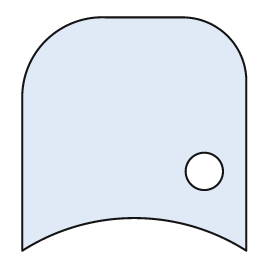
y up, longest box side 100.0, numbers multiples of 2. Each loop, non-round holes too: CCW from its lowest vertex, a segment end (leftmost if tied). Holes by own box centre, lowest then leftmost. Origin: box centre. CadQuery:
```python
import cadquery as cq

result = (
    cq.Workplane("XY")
    .moveTo(-48.0, -50.0)
    .threePointArc((0.0, -36.0), (48.0, -50.0))
    .lineTo(48.0, 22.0)
    .threePointArc((40.0, 42.0), (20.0, 50.0))
    .lineTo(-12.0, 50.0)
    .threePointArc((-38.0, 40.0), (-48.0, 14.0))
    .close()
    .moveTo(30.0, -16.0)
    .circle(8.0)
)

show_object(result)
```